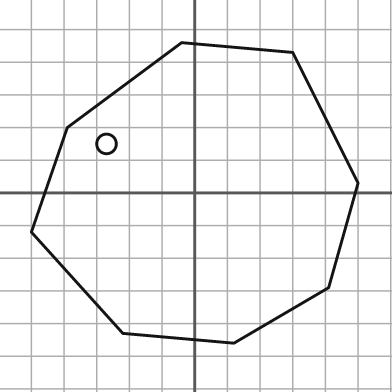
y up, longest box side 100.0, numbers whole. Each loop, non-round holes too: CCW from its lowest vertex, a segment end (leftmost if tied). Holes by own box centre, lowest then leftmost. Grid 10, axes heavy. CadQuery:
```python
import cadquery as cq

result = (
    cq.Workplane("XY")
    .moveTo(12.0, -46.0)
    .lineTo(41.0, -29.0)
    .lineTo(50.0, 3.0)
    .lineTo(30.0, 43.0)
    .lineTo(-4.0, 46.0)
    .lineTo(-39.0, 20.0)
    .lineTo(-50.0, -12.0)
    .lineTo(-22.0, -43.0)
    .close()
    .moveTo(-27.0, 15.0)
    .circle(3.0)
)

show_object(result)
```